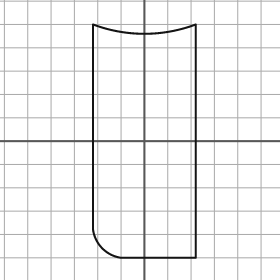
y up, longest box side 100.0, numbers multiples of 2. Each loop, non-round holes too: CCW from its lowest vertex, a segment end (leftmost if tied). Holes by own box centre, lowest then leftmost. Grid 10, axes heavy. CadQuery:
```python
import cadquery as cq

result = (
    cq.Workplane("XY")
    .moveTo(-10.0, -50.0)
    .lineTo(22.0, -50.0)
    .lineTo(22.0, 50.0)
    .threePointArc((0.0, 46.0), (-22.0, 50.0))
    .lineTo(-22.0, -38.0)
    .threePointArc((-18.0, -46.0), (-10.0, -50.0))
    .close()
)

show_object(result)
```